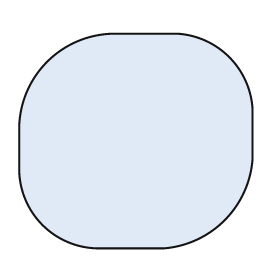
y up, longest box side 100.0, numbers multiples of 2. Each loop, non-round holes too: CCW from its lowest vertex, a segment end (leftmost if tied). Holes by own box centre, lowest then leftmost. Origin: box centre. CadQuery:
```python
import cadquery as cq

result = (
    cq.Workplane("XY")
    .moveTo(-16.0, -46.0)
    .lineTo(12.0, -46.0)
    .threePointArc((38.0, -34.0), (50.0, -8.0))
    .lineTo(50.0, 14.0)
    .threePointArc((40.0, 36.0), (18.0, 46.0))
    .lineTo(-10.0, 46.0)
    .threePointArc((-38.0, 34.0), (-50.0, 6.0))
    .lineTo(-50.0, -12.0)
    .threePointArc((-40.0, -36.0), (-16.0, -46.0))
    .close()
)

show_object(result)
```